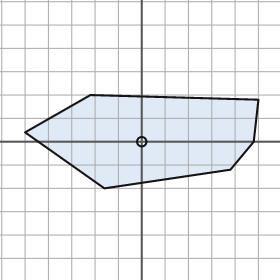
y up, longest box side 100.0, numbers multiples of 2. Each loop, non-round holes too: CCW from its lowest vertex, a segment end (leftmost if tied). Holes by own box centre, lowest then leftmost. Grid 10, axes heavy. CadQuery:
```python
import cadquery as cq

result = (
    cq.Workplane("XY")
    .moveTo(-16.0, -20.0)
    .lineTo(38.0, -12.0)
    .lineTo(48.0, 0.0)
    .lineTo(50.0, 18.0)
    .lineTo(-22.0, 20.0)
    .lineTo(-50.0, 4.0)
    .close()
    .moveTo(0.0, 0.0)
    .circle(2.0)
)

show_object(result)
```